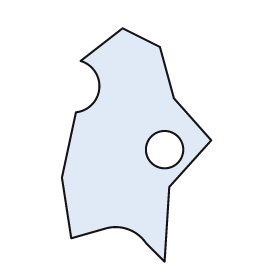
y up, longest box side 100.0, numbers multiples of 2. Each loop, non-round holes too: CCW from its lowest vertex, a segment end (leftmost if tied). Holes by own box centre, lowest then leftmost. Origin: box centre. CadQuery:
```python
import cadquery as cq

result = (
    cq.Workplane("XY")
    .moveTo(12.0, -50.0)
    .lineTo(14.0, -18.0)
    .lineTo(32.0, 2.0)
    .lineTo(16.0, 20.0)
    .lineTo(10.0, 42.0)
    .lineTo(-6.0, 50.0)
    .lineTo(-24.0, 36.0)
    .threePointArc((-16.0, 24.0), (-26.0, 14.0))
    .lineTo(-32.0, -14.0)
    .lineTo(-28.0, -40.0)
    .lineTo(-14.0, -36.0)
    .threePointArc((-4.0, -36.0), (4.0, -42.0))
    .close()
    .moveTo(12.0, -2.0)
    .circle(8.0)
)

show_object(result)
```